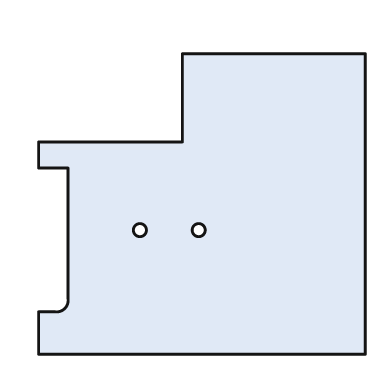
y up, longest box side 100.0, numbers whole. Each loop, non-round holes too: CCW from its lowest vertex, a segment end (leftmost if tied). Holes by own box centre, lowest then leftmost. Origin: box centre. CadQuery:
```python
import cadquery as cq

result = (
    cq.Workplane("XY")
    .moveTo(-50.0, -46.0)
    .lineTo(50.0, -46.0)
    .lineTo(50.0, 46.0)
    .lineTo(-6.0, 46.0)
    .lineTo(-6.0, 19.0)
    .lineTo(-50.0, 19.0)
    .lineTo(-50.0, 11.0)
    .lineTo(-41.0, 11.0)
    .lineTo(-41.0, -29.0)
    .threePointArc((-42.0, -32.0), (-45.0, -33.0))
    .lineTo(-50.0, -33.0)
    .close()
    .moveTo(-19.0, -8.0)
    .circle(2.0)
    .moveTo(-1.0, -8.0)
    .circle(2.0)
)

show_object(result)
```